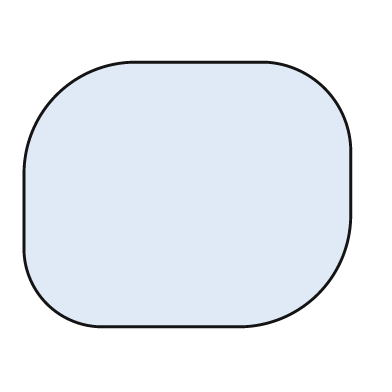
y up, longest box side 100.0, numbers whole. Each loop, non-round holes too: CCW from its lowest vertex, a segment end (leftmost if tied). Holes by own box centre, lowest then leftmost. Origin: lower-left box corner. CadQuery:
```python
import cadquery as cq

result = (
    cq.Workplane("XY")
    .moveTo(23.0, 0.0)
    .lineTo(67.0, 0.0)
    .threePointArc((90.0, 10.0), (100.0, 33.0))
    .lineTo(100.0, 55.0)
    .threePointArc((92.0, 73.0), (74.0, 81.0))
    .lineTo(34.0, 81.0)
    .threePointArc((10.0, 71.0), (0.0, 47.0))
    .lineTo(0.0, 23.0)
    .threePointArc((7.0, 7.0), (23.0, 0.0))
    .close()
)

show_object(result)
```